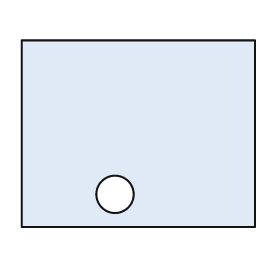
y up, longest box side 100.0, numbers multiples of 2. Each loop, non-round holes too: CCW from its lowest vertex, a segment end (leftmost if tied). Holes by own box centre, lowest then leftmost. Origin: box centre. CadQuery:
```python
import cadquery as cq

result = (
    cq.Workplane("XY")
    .moveTo(-50.0, -40.0)
    .lineTo(50.0, -40.0)
    .lineTo(50.0, 40.0)
    .lineTo(-50.0, 40.0)
    .close()
    .moveTo(-10.0, -26.0)
    .circle(8.0)
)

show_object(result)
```